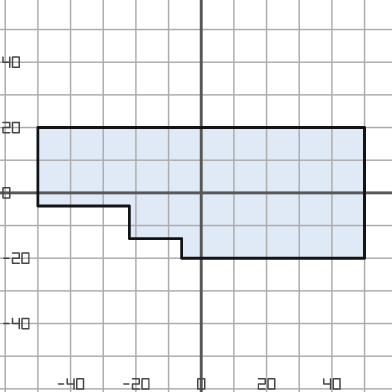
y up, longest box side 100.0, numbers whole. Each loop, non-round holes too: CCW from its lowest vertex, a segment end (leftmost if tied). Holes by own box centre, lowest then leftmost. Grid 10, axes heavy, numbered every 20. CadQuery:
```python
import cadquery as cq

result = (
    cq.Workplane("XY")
    .moveTo(-6.0, -20.0)
    .lineTo(50.0, -20.0)
    .lineTo(50.0, 20.0)
    .lineTo(-50.0, 20.0)
    .lineTo(-50.0, -4.0)
    .lineTo(-22.0, -4.0)
    .lineTo(-22.0, -14.0)
    .lineTo(-6.0, -14.0)
    .close()
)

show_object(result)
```